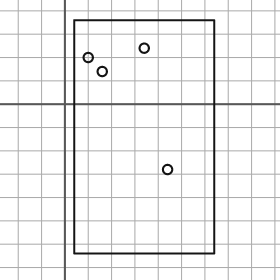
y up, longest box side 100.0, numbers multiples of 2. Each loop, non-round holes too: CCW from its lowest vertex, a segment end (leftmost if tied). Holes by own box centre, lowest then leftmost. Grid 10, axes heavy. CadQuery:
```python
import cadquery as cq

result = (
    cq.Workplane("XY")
    .moveTo(4.0, -64.0)
    .lineTo(64.0, -64.0)
    .lineTo(64.0, 36.0)
    .lineTo(4.0, 36.0)
    .close()
    .moveTo(44.0, -28.0)
    .circle(2.0)
    .moveTo(16.0, 14.0)
    .circle(2.0)
    .moveTo(10.0, 20.0)
    .circle(2.0)
    .moveTo(34.0, 24.0)
    .circle(2.0)
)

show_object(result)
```